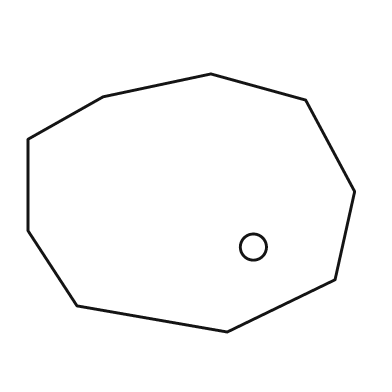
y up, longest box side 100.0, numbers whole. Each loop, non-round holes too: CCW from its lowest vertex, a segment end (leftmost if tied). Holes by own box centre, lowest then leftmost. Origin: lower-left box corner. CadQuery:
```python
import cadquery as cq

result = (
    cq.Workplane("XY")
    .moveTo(61.0, 0.0)
    .lineTo(94.0, 16.0)
    .lineTo(100.0, 43.0)
    .lineTo(85.0, 71.0)
    .lineTo(56.0, 79.0)
    .lineTo(23.0, 72.0)
    .lineTo(0.0, 59.0)
    .lineTo(0.0, 31.0)
    .lineTo(15.0, 8.0)
    .close()
    .moveTo(69.0, 26.0)
    .circle(4.0)
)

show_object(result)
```